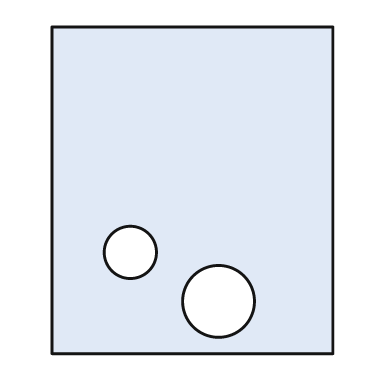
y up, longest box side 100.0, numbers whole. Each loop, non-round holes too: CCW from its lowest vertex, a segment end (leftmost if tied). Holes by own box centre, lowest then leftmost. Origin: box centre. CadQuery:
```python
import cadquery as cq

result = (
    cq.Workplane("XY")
    .moveTo(-43.0, -50.0)
    .lineTo(43.0, -50.0)
    .lineTo(43.0, 50.0)
    .lineTo(-43.0, 50.0)
    .close()
    .moveTo(8.0, -34.0)
    .circle(11.0)
    .moveTo(-19.0, -19.0)
    .circle(8.0)
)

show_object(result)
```